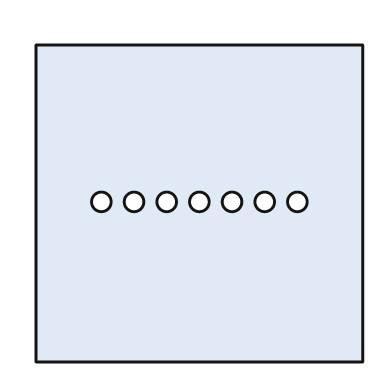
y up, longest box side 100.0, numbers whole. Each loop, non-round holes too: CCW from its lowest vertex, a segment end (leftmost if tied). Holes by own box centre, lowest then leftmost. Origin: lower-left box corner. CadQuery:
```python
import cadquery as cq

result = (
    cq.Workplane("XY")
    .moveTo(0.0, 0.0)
    .lineTo(100.0, 0.0)
    .lineTo(100.0, 97.0)
    .lineTo(0.0, 97.0)
    .close()
    .moveTo(20.0, 49.0)
    .circle(3.0)
    .moveTo(30.0, 49.0)
    .circle(3.0)
    .moveTo(40.0, 49.0)
    .circle(3.0)
    .moveTo(50.0, 49.0)
    .circle(3.0)
    .moveTo(60.0, 49.0)
    .circle(3.0)
    .moveTo(70.0, 49.0)
    .circle(3.0)
    .moveTo(80.0, 49.0)
    .circle(3.0)
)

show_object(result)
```